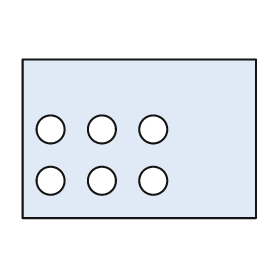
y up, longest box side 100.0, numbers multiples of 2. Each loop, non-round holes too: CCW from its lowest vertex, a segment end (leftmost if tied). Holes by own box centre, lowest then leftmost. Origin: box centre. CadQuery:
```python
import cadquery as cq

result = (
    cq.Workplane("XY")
    .moveTo(-50.0, -34.0)
    .lineTo(50.0, -34.0)
    .lineTo(50.0, 34.0)
    .lineTo(-50.0, 34.0)
    .close()
    .moveTo(-38.0, -18.0)
    .circle(6.0)
    .moveTo(-16.0, -18.0)
    .circle(6.0)
    .moveTo(6.0, -18.0)
    .circle(6.0)
    .moveTo(-38.0, 4.0)
    .circle(6.0)
    .moveTo(-16.0, 4.0)
    .circle(6.0)
    .moveTo(6.0, 4.0)
    .circle(6.0)
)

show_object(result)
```